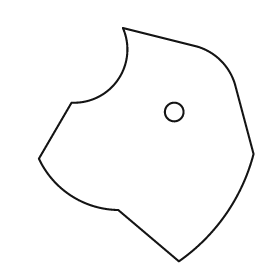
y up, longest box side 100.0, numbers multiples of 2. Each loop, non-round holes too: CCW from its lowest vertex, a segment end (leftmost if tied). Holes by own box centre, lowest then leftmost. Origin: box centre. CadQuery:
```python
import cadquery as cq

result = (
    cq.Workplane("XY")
    .moveTo(14.0, -50.0)
    .threePointArc((34.0, -30.0), (46.0, -4.0))
    .lineTo(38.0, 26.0)
    .threePointArc((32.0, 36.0), (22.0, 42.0))
    .lineTo(-10.0, 50.0)
    .threePointArc((-12.0, 28.0), (-32.0, 18.0))
    .lineTo(-46.0, -6.0)
    .threePointArc((-32.0, -22.0), (-12.0, -28.0))
    .close()
    .moveTo(12.0, 14.0)
    .circle(4.0)
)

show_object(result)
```